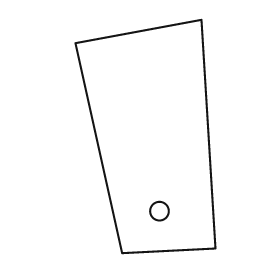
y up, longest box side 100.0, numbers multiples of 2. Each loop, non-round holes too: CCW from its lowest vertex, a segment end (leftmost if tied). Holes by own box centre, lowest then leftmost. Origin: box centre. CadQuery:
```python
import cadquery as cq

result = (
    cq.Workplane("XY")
    .moveTo(-10.0, -50.0)
    .lineTo(30.0, -48.0)
    .lineTo(24.0, 50.0)
    .lineTo(-30.0, 40.0)
    .close()
    .moveTo(6.0, -32.0)
    .circle(4.0)
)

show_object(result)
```